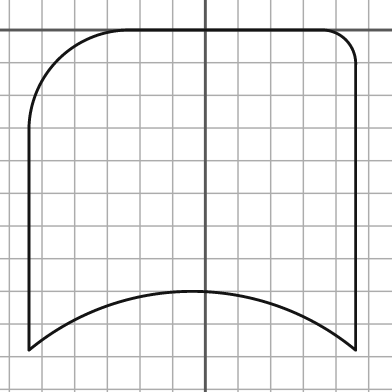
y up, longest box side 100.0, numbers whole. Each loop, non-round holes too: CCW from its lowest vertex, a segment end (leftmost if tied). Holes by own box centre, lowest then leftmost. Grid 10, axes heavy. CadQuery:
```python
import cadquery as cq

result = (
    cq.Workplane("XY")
    .moveTo(-54.0, -98.0)
    .threePointArc((-4.0, -80.0), (46.0, -98.0))
    .lineTo(46.0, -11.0)
    .threePointArc((43.0, -3.0), (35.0, 0.0))
    .lineTo(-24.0, 0.0)
    .threePointArc((-45.0, -9.0), (-54.0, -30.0))
    .close()
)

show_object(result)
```